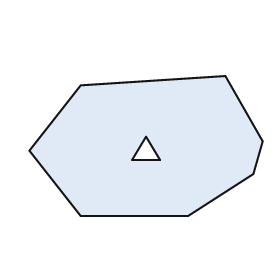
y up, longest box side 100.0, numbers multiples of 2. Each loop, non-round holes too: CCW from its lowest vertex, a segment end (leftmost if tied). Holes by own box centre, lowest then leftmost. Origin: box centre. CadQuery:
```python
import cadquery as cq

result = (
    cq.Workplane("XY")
    .moveTo(-28.0, -30.0)
    .lineTo(18.0, -30.0)
    .lineTo(46.0, -12.0)
    .lineTo(50.0, 2.0)
    .lineTo(34.0, 30.0)
    .lineTo(-28.0, 26.0)
    .lineTo(-50.0, -2.0)
    .close()
    .moveTo(-6.0, -6.0)
    .lineTo(6.0, -6.0)
    .lineTo(0.0, 4.0)
    .close()
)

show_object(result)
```